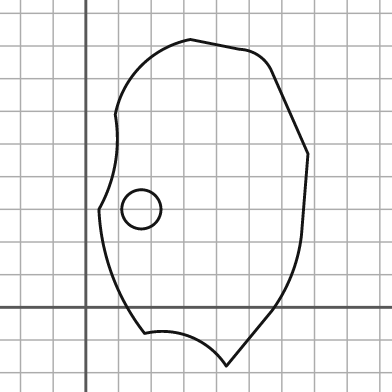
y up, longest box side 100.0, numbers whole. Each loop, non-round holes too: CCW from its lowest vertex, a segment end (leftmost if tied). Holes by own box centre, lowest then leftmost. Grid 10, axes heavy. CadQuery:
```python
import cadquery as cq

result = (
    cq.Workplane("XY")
    .moveTo(43.0, -18.0)
    .lineTo(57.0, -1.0)
    .threePointArc((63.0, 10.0), (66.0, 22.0))
    .lineTo(68.0, 47.0)
    .lineTo(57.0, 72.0)
    .threePointArc((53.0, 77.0), (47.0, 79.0))
    .lineTo(32.0, 82.0)
    .threePointArc((17.0, 74.0), (9.0, 59.0))
    .threePointArc((9.0, 44.0), (4.0, 30.0))
    .threePointArc((8.0, 10.0), (18.0, -8.0))
    .threePointArc((32.0, -9.0), (43.0, -18.0))
    .close()
    .moveTo(17.0, 30.0)
    .circle(6.0)
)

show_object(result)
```